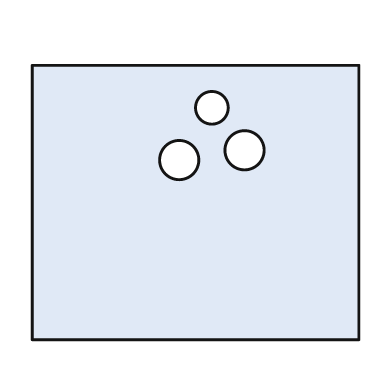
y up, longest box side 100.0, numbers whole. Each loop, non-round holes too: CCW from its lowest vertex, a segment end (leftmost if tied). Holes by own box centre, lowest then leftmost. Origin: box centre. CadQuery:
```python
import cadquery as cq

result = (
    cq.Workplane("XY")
    .moveTo(-50.0, -42.0)
    .lineTo(50.0, -42.0)
    .lineTo(50.0, 42.0)
    .lineTo(-50.0, 42.0)
    .close()
    .moveTo(-5.0, 13.0)
    .circle(6.0)
    .moveTo(15.0, 16.0)
    .circle(6.0)
    .moveTo(5.0, 29.0)
    .circle(5.0)
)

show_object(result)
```